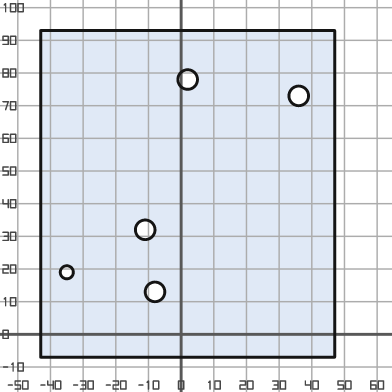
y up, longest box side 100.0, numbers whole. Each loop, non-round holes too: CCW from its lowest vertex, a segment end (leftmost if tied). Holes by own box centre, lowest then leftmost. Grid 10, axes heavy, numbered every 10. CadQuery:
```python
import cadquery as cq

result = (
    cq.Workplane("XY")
    .moveTo(-43.0, -7.0)
    .lineTo(47.0, -7.0)
    .lineTo(47.0, 93.0)
    .lineTo(-43.0, 93.0)
    .close()
    .moveTo(-8.0, 13.0)
    .circle(3.0)
    .moveTo(-35.0, 19.0)
    .circle(2.0)
    .moveTo(-11.0, 32.0)
    .circle(3.0)
    .moveTo(36.0, 73.0)
    .circle(3.0)
    .moveTo(2.0, 78.0)
    .circle(3.0)
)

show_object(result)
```